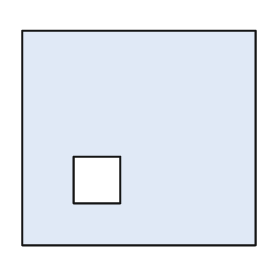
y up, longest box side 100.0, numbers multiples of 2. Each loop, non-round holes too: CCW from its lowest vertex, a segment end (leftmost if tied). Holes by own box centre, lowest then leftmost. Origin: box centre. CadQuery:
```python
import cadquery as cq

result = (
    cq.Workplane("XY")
    .moveTo(-50.0, -46.0)
    .lineTo(50.0, -46.0)
    .lineTo(50.0, 46.0)
    .lineTo(-50.0, 46.0)
    .close()
    .moveTo(-28.0, -28.0)
    .lineTo(-8.0, -28.0)
    .lineTo(-8.0, -8.0)
    .lineTo(-28.0, -8.0)
    .close()
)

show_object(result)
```